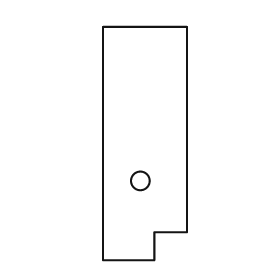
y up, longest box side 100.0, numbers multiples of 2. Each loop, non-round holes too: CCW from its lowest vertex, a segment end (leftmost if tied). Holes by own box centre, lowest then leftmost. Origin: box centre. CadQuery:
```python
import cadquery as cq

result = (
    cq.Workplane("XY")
    .moveTo(-18.0, -50.0)
    .lineTo(4.0, -50.0)
    .lineTo(4.0, -38.0)
    .lineTo(18.0, -38.0)
    .lineTo(18.0, 50.0)
    .lineTo(-18.0, 50.0)
    .close()
    .moveTo(-2.0, -16.0)
    .circle(4.0)
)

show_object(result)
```